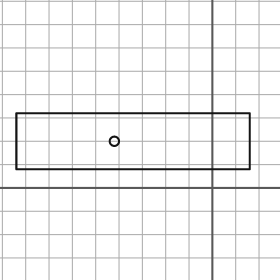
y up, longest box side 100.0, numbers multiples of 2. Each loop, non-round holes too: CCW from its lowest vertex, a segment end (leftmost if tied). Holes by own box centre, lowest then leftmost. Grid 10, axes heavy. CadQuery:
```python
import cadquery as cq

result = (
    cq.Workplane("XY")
    .moveTo(-84.0, 8.0)
    .lineTo(16.0, 8.0)
    .lineTo(16.0, 32.0)
    .lineTo(-84.0, 32.0)
    .close()
    .moveTo(-42.0, 20.0)
    .circle(2.0)
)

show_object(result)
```